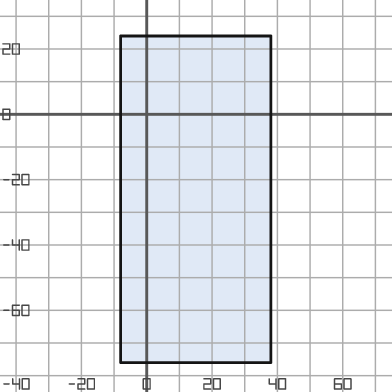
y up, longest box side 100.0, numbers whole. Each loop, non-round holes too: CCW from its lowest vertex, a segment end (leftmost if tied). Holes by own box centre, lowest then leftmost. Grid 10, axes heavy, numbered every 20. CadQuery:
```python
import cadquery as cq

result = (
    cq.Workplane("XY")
    .moveTo(-8.0, -76.0)
    .lineTo(38.0, -76.0)
    .lineTo(38.0, 24.0)
    .lineTo(-8.0, 24.0)
    .close()
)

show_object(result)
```